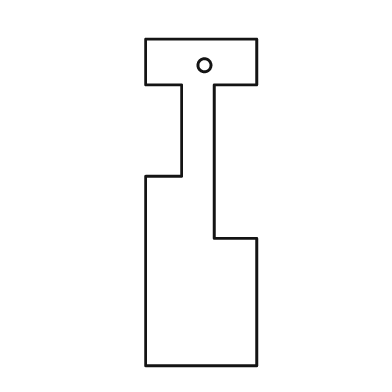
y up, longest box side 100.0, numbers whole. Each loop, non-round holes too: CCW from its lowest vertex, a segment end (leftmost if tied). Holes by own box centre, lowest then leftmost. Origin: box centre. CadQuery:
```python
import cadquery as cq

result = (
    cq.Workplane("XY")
    .moveTo(-17.0, -50.0)
    .lineTo(17.0, -50.0)
    .lineTo(17.0, -11.0)
    .lineTo(4.0, -11.0)
    .lineTo(4.0, 36.0)
    .lineTo(17.0, 36.0)
    .lineTo(17.0, 50.0)
    .lineTo(-17.0, 50.0)
    .lineTo(-17.0, 36.0)
    .lineTo(-6.0, 36.0)
    .lineTo(-6.0, 8.0)
    .lineTo(-17.0, 8.0)
    .close()
    .moveTo(1.0, 42.0)
    .circle(2.0)
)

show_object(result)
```